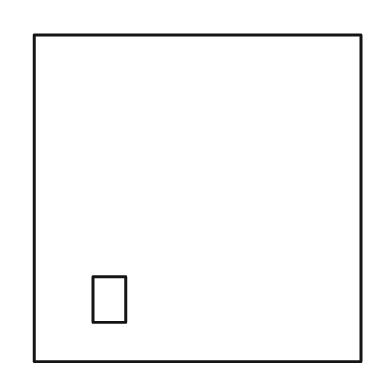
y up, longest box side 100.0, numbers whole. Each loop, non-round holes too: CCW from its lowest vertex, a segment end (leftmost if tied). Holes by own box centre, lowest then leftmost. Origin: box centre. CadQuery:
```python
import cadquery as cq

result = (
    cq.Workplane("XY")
    .moveTo(-50.0, -50.0)
    .lineTo(50.0, -50.0)
    .lineTo(50.0, 50.0)
    .lineTo(-50.0, 50.0)
    .close()
    .moveTo(-32.0, -38.0)
    .lineTo(-22.0, -38.0)
    .lineTo(-22.0, -24.0)
    .lineTo(-32.0, -24.0)
    .close()
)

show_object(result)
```